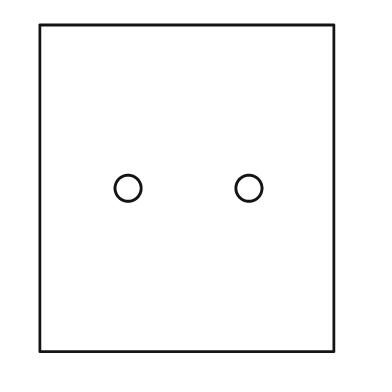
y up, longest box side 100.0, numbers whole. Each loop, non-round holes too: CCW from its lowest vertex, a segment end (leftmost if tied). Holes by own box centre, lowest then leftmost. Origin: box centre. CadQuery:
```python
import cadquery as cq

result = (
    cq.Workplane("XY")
    .moveTo(-45.0, -50.0)
    .lineTo(45.0, -50.0)
    .lineTo(45.0, 50.0)
    .lineTo(-45.0, 50.0)
    .close()
    .moveTo(-18.0, 0.0)
    .circle(4.0)
    .moveTo(19.0, 0.0)
    .circle(4.0)
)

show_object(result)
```